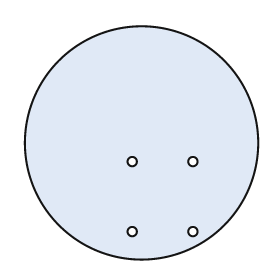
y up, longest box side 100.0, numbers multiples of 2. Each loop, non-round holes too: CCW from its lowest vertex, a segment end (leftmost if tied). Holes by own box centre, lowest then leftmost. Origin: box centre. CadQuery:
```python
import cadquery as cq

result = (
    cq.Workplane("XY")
    .moveTo(0.0, 0.0)
    .circle(50.0)
    .moveTo(-4.0, -38.0)
    .circle(2.0)
    .moveTo(22.0, -38.0)
    .circle(2.0)
    .moveTo(-4.0, -8.0)
    .circle(2.0)
    .moveTo(22.0, -8.0)
    .circle(2.0)
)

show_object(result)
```